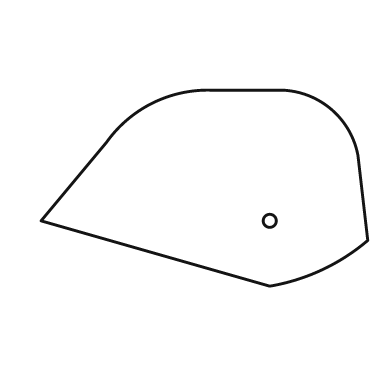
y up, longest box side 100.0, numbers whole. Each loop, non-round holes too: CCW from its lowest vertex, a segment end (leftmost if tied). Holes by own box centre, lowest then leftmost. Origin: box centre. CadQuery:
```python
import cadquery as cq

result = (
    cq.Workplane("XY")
    .moveTo(20.0, -30.0)
    .threePointArc((36.0, -25.0), (50.0, -16.0))
    .lineTo(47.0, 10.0)
    .threePointArc((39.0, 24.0), (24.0, 30.0))
    .lineTo(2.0, 30.0)
    .threePointArc((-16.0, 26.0), (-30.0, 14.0))
    .lineTo(-50.0, -10.0)
    .close()
    .moveTo(20.0, -10.0)
    .circle(2.0)
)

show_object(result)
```